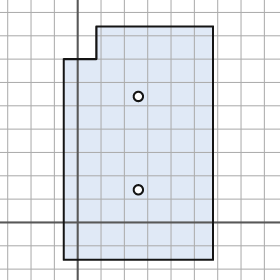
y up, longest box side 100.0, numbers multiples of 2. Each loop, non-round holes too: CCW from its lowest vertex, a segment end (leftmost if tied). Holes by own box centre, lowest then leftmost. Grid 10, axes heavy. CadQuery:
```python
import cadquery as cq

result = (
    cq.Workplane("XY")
    .moveTo(-6.0, -16.0)
    .lineTo(58.0, -16.0)
    .lineTo(58.0, 84.0)
    .lineTo(8.0, 84.0)
    .lineTo(8.0, 70.0)
    .lineTo(-6.0, 70.0)
    .close()
    .moveTo(26.0, 14.0)
    .circle(2.0)
    .moveTo(26.0, 54.0)
    .circle(2.0)
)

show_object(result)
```